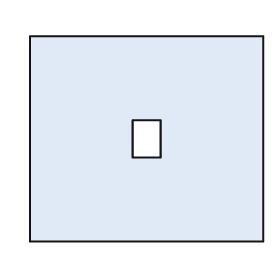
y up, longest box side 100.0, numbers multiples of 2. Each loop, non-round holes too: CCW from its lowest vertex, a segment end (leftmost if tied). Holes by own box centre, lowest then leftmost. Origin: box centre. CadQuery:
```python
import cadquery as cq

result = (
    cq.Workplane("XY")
    .moveTo(-50.0, -44.0)
    .lineTo(50.0, -44.0)
    .lineTo(50.0, 44.0)
    .lineTo(-50.0, 44.0)
    .close()
    .moveTo(-6.0, -8.0)
    .lineTo(6.0, -8.0)
    .lineTo(6.0, 8.0)
    .lineTo(-6.0, 8.0)
    .close()
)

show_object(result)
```